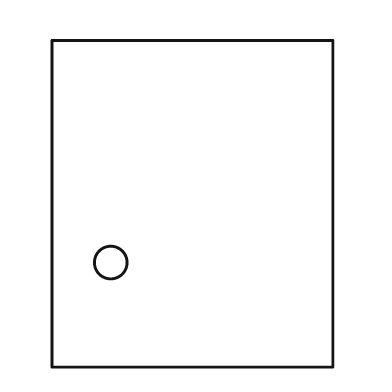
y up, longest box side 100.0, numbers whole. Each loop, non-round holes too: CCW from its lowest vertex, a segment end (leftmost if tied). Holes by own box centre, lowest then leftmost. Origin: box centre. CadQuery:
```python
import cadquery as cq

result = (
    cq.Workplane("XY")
    .moveTo(-43.0, -50.0)
    .lineTo(43.0, -50.0)
    .lineTo(43.0, 50.0)
    .lineTo(-43.0, 50.0)
    .close()
    .moveTo(-25.0, -18.0)
    .circle(5.0)
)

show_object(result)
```